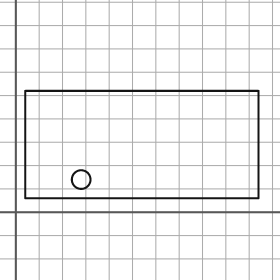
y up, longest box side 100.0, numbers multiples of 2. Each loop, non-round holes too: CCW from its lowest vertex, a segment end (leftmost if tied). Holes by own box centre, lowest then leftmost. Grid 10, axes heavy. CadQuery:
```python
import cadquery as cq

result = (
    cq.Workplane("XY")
    .moveTo(4.0, 6.0)
    .lineTo(104.0, 6.0)
    .lineTo(104.0, 52.0)
    .lineTo(4.0, 52.0)
    .close()
    .moveTo(28.0, 14.0)
    .circle(4.0)
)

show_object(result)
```